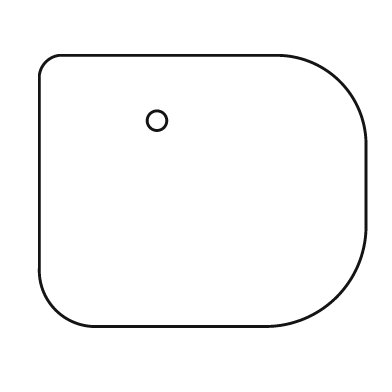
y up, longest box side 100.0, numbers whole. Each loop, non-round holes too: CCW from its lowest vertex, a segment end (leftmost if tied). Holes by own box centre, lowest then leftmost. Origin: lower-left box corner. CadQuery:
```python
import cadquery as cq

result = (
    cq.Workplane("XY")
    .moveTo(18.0, 0.0)
    .lineTo(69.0, 0.0)
    .threePointArc((91.0, 9.0), (100.0, 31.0))
    .lineTo(100.0, 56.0)
    .threePointArc((92.0, 75.0), (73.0, 83.0))
    .lineTo(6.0, 83.0)
    .threePointArc((2.0, 81.0), (0.0, 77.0))
    .lineTo(0.0, 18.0)
    .threePointArc((5.0, 5.0), (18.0, 0.0))
    .close()
    .moveTo(36.0, 63.0)
    .circle(3.0)
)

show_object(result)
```